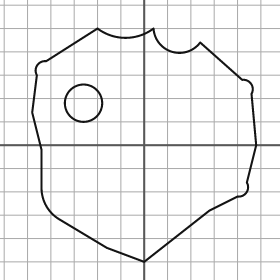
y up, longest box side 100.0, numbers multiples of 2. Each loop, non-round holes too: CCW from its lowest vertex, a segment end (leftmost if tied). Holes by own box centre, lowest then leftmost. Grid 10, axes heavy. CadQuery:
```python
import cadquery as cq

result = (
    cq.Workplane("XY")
    .moveTo(0.0, -50.0)
    .lineTo(28.0, -28.0)
    .lineTo(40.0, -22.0)
    .threePointArc((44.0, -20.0), (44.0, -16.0))
    .lineTo(48.0, 0.0)
    .lineTo(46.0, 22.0)
    .threePointArc((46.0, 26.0), (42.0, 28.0))
    .lineTo(24.0, 44.0)
    .threePointArc((12.0, 40.0), (4.0, 50.0))
    .threePointArc((-8.0, 46.0), (-20.0, 50.0))
    .lineTo(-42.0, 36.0)
    .threePointArc((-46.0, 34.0), (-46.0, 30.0))
    .lineTo(-48.0, 14.0)
    .lineTo(-44.0, -2.0)
    .lineTo(-44.0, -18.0)
    .threePointArc((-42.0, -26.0), (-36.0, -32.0))
    .lineTo(-16.0, -44.0)
    .close()
    .moveTo(-26.0, 18.0)
    .circle(8.0)
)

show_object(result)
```